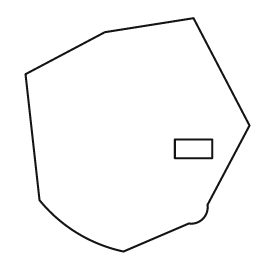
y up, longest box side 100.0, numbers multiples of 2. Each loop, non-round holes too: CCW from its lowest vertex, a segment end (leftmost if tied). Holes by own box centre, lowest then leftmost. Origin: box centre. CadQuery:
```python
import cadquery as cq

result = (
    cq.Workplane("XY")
    .moveTo(-6.0, -50.0)
    .lineTo(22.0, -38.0)
    .threePointArc((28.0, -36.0), (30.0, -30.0))
    .lineTo(48.0, 4.0)
    .lineTo(24.0, 50.0)
    .lineTo(-14.0, 44.0)
    .lineTo(-48.0, 26.0)
    .lineTo(-42.0, -28.0)
    .threePointArc((-26.0, -42.0), (-6.0, -50.0))
    .close()
    .moveTo(16.0, -10.0)
    .lineTo(32.0, -10.0)
    .lineTo(32.0, -2.0)
    .lineTo(16.0, -2.0)
    .close()
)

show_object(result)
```